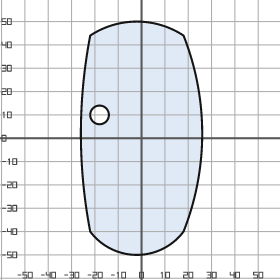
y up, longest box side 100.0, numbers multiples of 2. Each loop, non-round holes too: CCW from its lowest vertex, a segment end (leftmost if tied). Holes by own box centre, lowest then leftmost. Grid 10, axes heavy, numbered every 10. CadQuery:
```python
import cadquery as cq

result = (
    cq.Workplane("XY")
    .moveTo(-22.0, -40.0)
    .threePointArc((-2.0, -50.0), (18.0, -40.0))
    .threePointArc((26.0, 2.0), (18.0, 44.0))
    .threePointArc((-2.0, 50.0), (-22.0, 44.0))
    .threePointArc((-26.0, 2.0), (-22.0, -40.0))
    .close()
    .moveTo(-18.0, 10.0)
    .circle(4.0)
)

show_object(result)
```